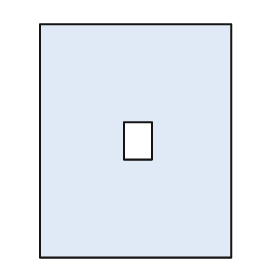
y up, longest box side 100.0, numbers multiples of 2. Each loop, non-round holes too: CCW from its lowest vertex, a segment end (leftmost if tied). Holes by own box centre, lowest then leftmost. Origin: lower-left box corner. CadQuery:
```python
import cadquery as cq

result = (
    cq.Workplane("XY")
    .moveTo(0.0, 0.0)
    .lineTo(82.0, 0.0)
    .lineTo(82.0, 100.0)
    .lineTo(0.0, 100.0)
    .close()
    .moveTo(36.0, 42.0)
    .lineTo(48.0, 42.0)
    .lineTo(48.0, 58.0)
    .lineTo(36.0, 58.0)
    .close()
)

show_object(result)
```